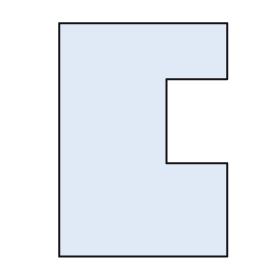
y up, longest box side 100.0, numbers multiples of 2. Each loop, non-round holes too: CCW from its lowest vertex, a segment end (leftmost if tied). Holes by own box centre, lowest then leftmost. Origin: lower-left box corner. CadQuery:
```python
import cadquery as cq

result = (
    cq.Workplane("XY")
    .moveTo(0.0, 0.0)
    .lineTo(72.0, 0.0)
    .lineTo(72.0, 40.0)
    .lineTo(46.0, 40.0)
    .lineTo(46.0, 76.0)
    .lineTo(72.0, 76.0)
    .lineTo(72.0, 100.0)
    .lineTo(0.0, 100.0)
    .close()
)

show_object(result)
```